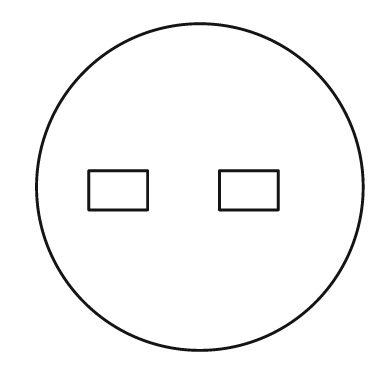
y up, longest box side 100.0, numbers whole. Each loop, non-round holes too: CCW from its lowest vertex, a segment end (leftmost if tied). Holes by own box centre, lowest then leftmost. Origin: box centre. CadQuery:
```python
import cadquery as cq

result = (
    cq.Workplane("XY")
    .moveTo(0.0, 0.0)
    .circle(50.0)
    .moveTo(-34.0, -7.0)
    .lineTo(-16.0, -7.0)
    .lineTo(-16.0, 5.0)
    .lineTo(-34.0, 5.0)
    .close()
    .moveTo(6.0, -7.0)
    .lineTo(24.0, -7.0)
    .lineTo(24.0, 5.0)
    .lineTo(6.0, 5.0)
    .close()
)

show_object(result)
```